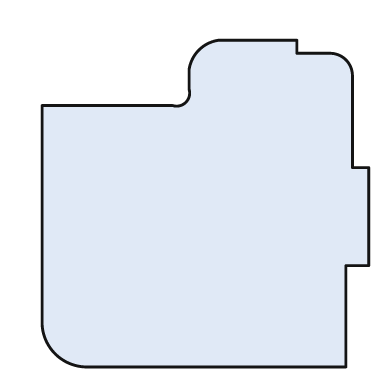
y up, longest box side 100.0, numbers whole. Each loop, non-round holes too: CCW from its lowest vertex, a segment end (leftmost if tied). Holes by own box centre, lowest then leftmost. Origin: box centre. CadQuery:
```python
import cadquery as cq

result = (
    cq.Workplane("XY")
    .moveTo(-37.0, -50.0)
    .lineTo(43.0, -50.0)
    .lineTo(43.0, -19.0)
    .lineTo(50.0, -19.0)
    .lineTo(50.0, 11.0)
    .lineTo(45.0, 11.0)
    .lineTo(45.0, 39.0)
    .threePointArc((43.0, 44.0), (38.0, 46.0))
    .lineTo(28.0, 46.0)
    .lineTo(28.0, 50.0)
    .lineTo(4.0, 50.0)
    .threePointArc((-2.0, 47.0), (-5.0, 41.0))
    .lineTo(-5.0, 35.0)
    .threePointArc((-6.0, 31.0), (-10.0, 30.0))
    .lineTo(-50.0, 30.0)
    .lineTo(-50.0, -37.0)
    .threePointArc((-46.0, -46.0), (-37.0, -50.0))
    .close()
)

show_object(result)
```